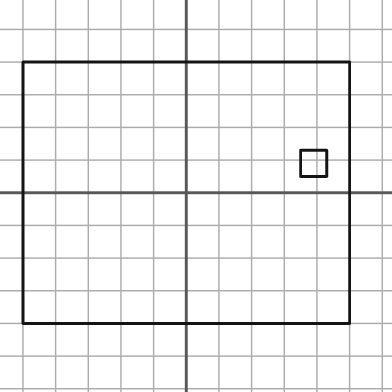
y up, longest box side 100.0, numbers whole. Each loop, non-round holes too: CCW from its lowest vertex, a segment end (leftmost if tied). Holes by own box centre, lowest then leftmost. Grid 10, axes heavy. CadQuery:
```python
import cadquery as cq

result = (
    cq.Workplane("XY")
    .moveTo(-50.0, -40.0)
    .lineTo(50.0, -40.0)
    .lineTo(50.0, 40.0)
    .lineTo(-50.0, 40.0)
    .close()
    .moveTo(35.0, 5.0)
    .lineTo(43.0, 5.0)
    .lineTo(43.0, 13.0)
    .lineTo(35.0, 13.0)
    .close()
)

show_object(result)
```